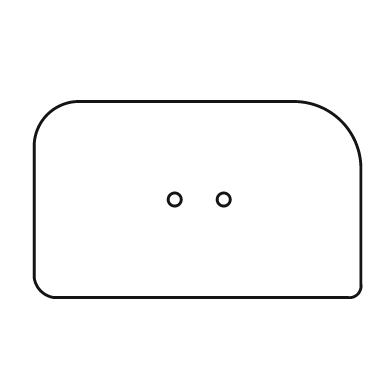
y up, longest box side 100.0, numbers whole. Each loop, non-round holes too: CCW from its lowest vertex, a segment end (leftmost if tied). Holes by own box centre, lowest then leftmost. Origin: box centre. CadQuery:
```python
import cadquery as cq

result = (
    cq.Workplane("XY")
    .moveTo(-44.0, -30.0)
    .lineTo(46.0, -30.0)
    .threePointArc((49.0, -29.0), (50.0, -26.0))
    .lineTo(50.0, 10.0)
    .threePointArc((44.0, 24.0), (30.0, 30.0))
    .lineTo(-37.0, 30.0)
    .threePointArc((-46.0, 26.0), (-50.0, 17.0))
    .lineTo(-50.0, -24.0)
    .threePointArc((-48.0, -28.0), (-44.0, -30.0))
    .close()
    .moveTo(-7.0, 0.0)
    .circle(2.0)
    .moveTo(8.0, 0.0)
    .circle(2.0)
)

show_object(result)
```